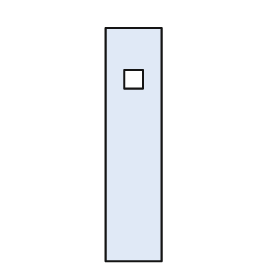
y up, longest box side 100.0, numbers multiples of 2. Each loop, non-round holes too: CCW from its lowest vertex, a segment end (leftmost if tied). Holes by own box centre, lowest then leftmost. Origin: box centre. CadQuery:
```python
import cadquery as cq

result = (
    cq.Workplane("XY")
    .moveTo(-12.0, -50.0)
    .lineTo(12.0, -50.0)
    .lineTo(12.0, 50.0)
    .lineTo(-12.0, 50.0)
    .close()
    .moveTo(-4.0, 24.0)
    .lineTo(4.0, 24.0)
    .lineTo(4.0, 32.0)
    .lineTo(-4.0, 32.0)
    .close()
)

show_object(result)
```